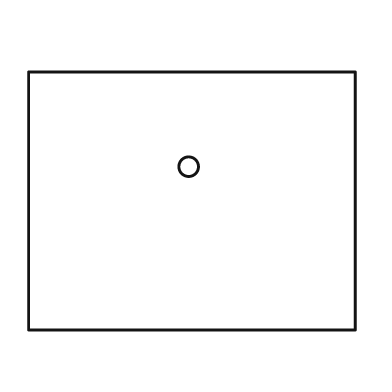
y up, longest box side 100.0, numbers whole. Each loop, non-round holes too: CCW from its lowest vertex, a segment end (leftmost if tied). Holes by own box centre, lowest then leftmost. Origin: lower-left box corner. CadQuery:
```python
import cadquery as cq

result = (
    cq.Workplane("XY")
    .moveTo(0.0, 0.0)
    .lineTo(100.0, 0.0)
    .lineTo(100.0, 79.0)
    .lineTo(0.0, 79.0)
    .close()
    .moveTo(49.0, 50.0)
    .circle(3.0)
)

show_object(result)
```